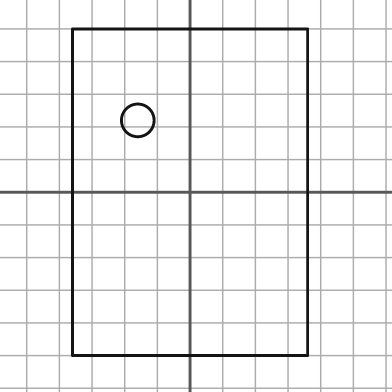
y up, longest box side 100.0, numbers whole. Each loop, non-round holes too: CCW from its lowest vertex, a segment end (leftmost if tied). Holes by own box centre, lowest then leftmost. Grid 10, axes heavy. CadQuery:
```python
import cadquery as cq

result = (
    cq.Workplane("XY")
    .moveTo(-36.0, -50.0)
    .lineTo(36.0, -50.0)
    .lineTo(36.0, 50.0)
    .lineTo(-36.0, 50.0)
    .close()
    .moveTo(-16.0, 22.0)
    .circle(5.0)
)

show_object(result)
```